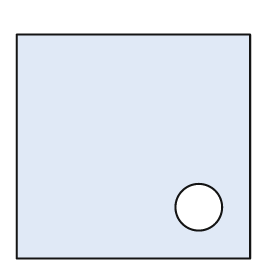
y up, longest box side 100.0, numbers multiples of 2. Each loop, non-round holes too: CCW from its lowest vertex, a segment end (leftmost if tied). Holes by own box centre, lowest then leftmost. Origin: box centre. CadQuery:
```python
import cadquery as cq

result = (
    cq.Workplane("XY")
    .moveTo(-50.0, -48.0)
    .lineTo(50.0, -48.0)
    .lineTo(50.0, 48.0)
    .lineTo(-50.0, 48.0)
    .close()
    .moveTo(28.0, -26.0)
    .circle(10.0)
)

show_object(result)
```